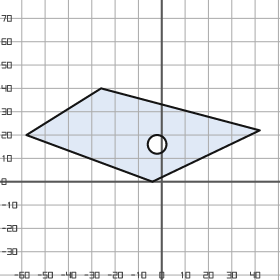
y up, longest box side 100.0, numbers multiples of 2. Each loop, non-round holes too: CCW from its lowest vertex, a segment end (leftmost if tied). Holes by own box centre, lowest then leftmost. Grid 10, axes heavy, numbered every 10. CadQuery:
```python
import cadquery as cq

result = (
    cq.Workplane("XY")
    .moveTo(-4.0, 0.0)
    .lineTo(42.0, 22.0)
    .lineTo(-26.0, 40.0)
    .lineTo(-58.0, 20.0)
    .close()
    .moveTo(-2.0, 16.0)
    .circle(4.0)
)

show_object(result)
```